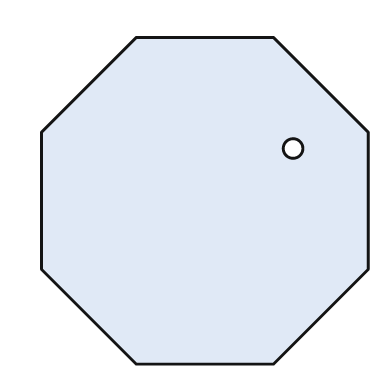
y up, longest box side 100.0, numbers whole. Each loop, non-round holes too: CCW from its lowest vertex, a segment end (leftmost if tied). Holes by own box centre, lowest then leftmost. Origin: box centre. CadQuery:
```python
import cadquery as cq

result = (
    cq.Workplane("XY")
    .moveTo(-21.0, -50.0)
    .lineTo(21.0, -50.0)
    .lineTo(50.0, -21.0)
    .lineTo(50.0, 21.0)
    .lineTo(21.0, 50.0)
    .lineTo(-21.0, 50.0)
    .lineTo(-50.0, 21.0)
    .lineTo(-50.0, -21.0)
    .close()
    .moveTo(27.0, 16.0)
    .circle(3.0)
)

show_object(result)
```